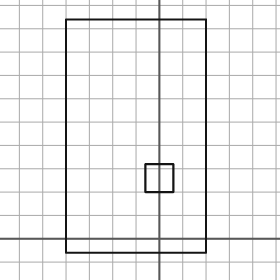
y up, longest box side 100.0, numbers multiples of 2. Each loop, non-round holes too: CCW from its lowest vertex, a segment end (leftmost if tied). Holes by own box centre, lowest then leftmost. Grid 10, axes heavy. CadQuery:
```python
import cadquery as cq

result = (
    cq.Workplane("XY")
    .moveTo(-40.0, -6.0)
    .lineTo(20.0, -6.0)
    .lineTo(20.0, 94.0)
    .lineTo(-40.0, 94.0)
    .close()
    .moveTo(-6.0, 20.0)
    .lineTo(6.0, 20.0)
    .lineTo(6.0, 32.0)
    .lineTo(-6.0, 32.0)
    .close()
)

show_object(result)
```